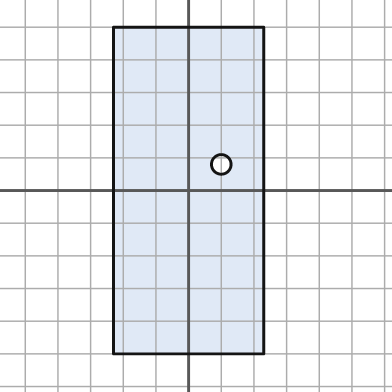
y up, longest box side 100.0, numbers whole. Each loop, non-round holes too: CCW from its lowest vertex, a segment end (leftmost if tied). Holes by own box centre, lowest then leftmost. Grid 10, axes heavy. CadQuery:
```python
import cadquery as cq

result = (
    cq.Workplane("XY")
    .moveTo(-23.0, -50.0)
    .lineTo(23.0, -50.0)
    .lineTo(23.0, 50.0)
    .lineTo(-23.0, 50.0)
    .close()
    .moveTo(10.0, 8.0)
    .circle(3.0)
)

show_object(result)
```